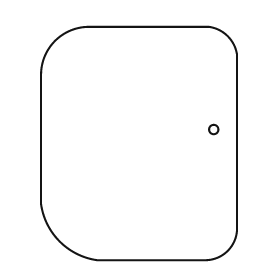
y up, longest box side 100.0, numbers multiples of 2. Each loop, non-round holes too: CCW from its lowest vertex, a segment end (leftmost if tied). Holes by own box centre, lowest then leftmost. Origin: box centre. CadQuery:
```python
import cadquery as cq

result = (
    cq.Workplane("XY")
    .moveTo(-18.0, -50.0)
    .lineTo(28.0, -50.0)
    .threePointArc((38.0, -46.0), (42.0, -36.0))
    .lineTo(42.0, 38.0)
    .threePointArc((38.0, 46.0), (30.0, 50.0))
    .lineTo(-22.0, 50.0)
    .threePointArc((-36.0, 44.0), (-42.0, 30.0))
    .lineTo(-42.0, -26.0)
    .threePointArc((-34.0, -42.0), (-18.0, -50.0))
    .close()
    .moveTo(32.0, 6.0)
    .circle(2.0)
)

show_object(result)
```